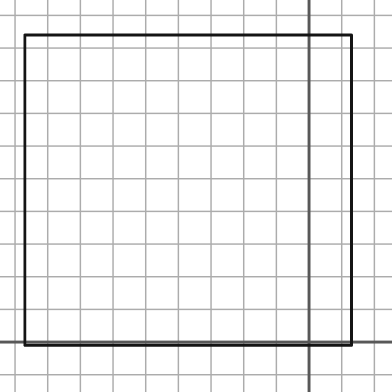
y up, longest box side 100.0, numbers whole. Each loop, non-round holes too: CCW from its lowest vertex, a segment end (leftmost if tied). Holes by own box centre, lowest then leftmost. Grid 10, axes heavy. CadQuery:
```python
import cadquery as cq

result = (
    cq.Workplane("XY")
    .moveTo(-87.0, -1.0)
    .lineTo(13.0, -1.0)
    .lineTo(13.0, 94.0)
    .lineTo(-87.0, 94.0)
    .close()
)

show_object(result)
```